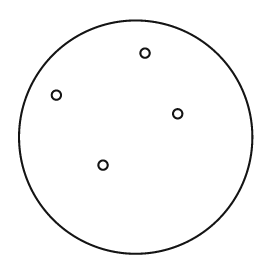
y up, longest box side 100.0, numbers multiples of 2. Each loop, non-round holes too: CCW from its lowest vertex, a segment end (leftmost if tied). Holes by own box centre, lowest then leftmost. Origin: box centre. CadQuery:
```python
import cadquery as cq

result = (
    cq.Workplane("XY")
    .moveTo(0.0, 0.0)
    .circle(50.0)
    .moveTo(-14.0, -12.0)
    .circle(2.0)
    .moveTo(18.0, 10.0)
    .circle(2.0)
    .moveTo(-34.0, 18.0)
    .circle(2.0)
    .moveTo(4.0, 36.0)
    .circle(2.0)
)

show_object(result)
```